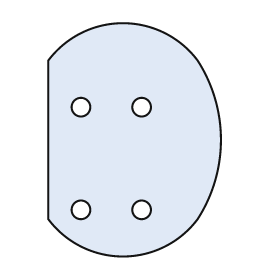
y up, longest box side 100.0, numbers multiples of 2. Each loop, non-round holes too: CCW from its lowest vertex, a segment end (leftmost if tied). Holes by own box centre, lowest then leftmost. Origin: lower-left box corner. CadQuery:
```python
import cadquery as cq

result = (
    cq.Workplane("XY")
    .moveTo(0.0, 16.0)
    .threePointArc((32.0, 0.0), (64.0, 16.0))
    .threePointArc((74.0, 50.0), (64.0, 84.0))
    .threePointArc((32.0, 100.0), (0.0, 84.0))
    .close()
    .moveTo(14.0, 20.0)
    .circle(4.0)
    .moveTo(40.0, 20.0)
    .circle(4.0)
    .moveTo(14.0, 64.0)
    .circle(4.0)
    .moveTo(40.0, 64.0)
    .circle(4.0)
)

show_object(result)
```